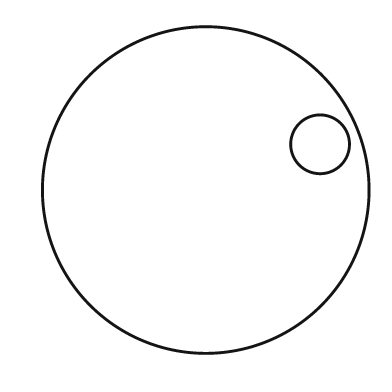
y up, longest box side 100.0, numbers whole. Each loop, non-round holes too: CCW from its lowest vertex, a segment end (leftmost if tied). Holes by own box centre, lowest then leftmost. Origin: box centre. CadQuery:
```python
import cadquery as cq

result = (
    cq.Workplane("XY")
    .moveTo(0.0, 0.0)
    .circle(50.0)
    .moveTo(35.0, 14.0)
    .circle(9.0)
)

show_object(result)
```